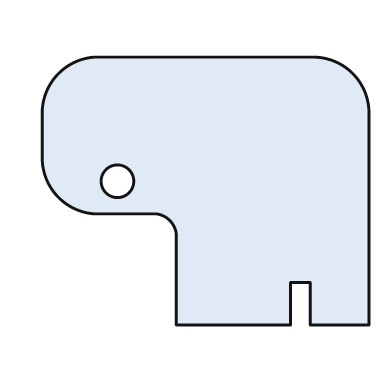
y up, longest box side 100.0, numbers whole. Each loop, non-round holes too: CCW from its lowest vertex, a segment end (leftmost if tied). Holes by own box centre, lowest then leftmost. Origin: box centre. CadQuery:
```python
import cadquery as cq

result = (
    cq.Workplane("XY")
    .moveTo(-9.0, -41.0)
    .lineTo(26.0, -41.0)
    .lineTo(26.0, -28.0)
    .lineTo(32.0, -28.0)
    .lineTo(32.0, -41.0)
    .lineTo(50.0, -41.0)
    .lineTo(50.0, 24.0)
    .threePointArc((45.0, 36.0), (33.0, 41.0))
    .lineTo(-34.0, 41.0)
    .threePointArc((-45.0, 36.0), (-50.0, 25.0))
    .lineTo(-50.0, 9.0)
    .threePointArc((-45.0, -2.0), (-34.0, -7.0))
    .lineTo(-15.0, -7.0)
    .threePointArc((-11.0, -9.0), (-9.0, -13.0))
    .close()
    .moveTo(-27.0, 3.0)
    .circle(5.0)
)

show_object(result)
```